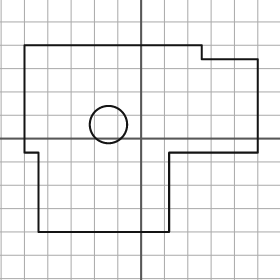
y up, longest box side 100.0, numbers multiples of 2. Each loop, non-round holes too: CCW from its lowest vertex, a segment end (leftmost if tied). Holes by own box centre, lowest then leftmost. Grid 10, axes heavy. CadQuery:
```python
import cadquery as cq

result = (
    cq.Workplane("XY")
    .moveTo(-44.0, -40.0)
    .lineTo(12.0, -40.0)
    .lineTo(12.0, -6.0)
    .lineTo(50.0, -6.0)
    .lineTo(50.0, 34.0)
    .lineTo(26.0, 34.0)
    .lineTo(26.0, 40.0)
    .lineTo(-50.0, 40.0)
    .lineTo(-50.0, -6.0)
    .lineTo(-44.0, -6.0)
    .close()
    .moveTo(-14.0, 6.0)
    .circle(8.0)
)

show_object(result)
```